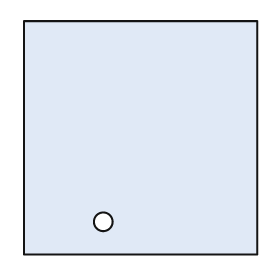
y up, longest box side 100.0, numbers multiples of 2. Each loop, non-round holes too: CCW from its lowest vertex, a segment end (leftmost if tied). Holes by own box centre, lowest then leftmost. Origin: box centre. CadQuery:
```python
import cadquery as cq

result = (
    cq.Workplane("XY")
    .moveTo(-50.0, -50.0)
    .lineTo(50.0, -50.0)
    .lineTo(50.0, 50.0)
    .lineTo(-50.0, 50.0)
    .close()
    .moveTo(-16.0, -36.0)
    .circle(4.0)
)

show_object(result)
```